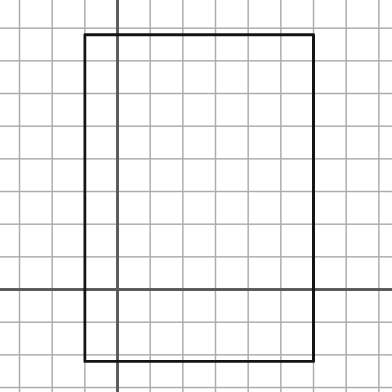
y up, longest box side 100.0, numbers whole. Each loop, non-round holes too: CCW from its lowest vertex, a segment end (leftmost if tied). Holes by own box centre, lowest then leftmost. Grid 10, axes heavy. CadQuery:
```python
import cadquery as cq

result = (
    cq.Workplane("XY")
    .moveTo(-10.0, -22.0)
    .lineTo(60.0, -22.0)
    .lineTo(60.0, 78.0)
    .lineTo(-10.0, 78.0)
    .close()
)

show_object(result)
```